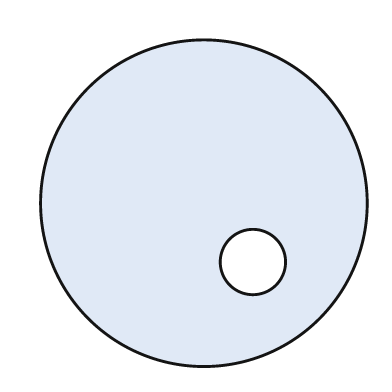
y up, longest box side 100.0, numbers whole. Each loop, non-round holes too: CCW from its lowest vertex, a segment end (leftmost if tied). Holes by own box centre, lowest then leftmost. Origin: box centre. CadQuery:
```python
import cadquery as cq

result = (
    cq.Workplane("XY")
    .moveTo(0.0, 0.0)
    .circle(50.0)
    .moveTo(15.0, -18.0)
    .circle(10.0)
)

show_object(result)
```